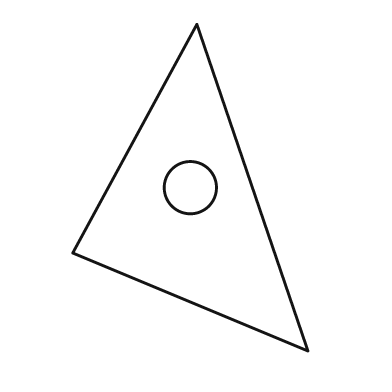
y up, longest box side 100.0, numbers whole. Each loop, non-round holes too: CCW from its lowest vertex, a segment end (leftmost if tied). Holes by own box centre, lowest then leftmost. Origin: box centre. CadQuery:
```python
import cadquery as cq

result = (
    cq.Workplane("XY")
    .moveTo(36.0, -50.0)
    .lineTo(2.0, 50.0)
    .lineTo(-36.0, -20.0)
    .close()
    .moveTo(0.0, 0.0)
    .circle(8.0)
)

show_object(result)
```